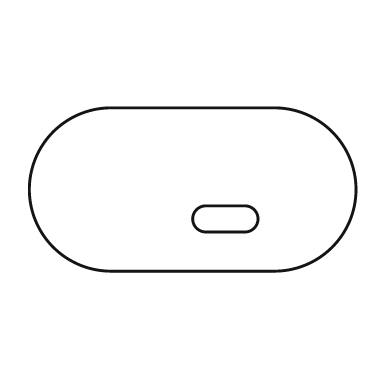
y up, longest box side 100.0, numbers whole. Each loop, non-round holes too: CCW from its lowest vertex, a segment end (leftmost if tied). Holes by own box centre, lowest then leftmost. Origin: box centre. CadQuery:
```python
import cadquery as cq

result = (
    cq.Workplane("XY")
    .moveTo(-25.0, -25.0)
    .lineTo(25.0, -25.0)
    .threePointArc((50.0, 0.0), (25.0, 25.0))
    .lineTo(-25.0, 25.0)
    .threePointArc((-50.0, 0.0), (-25.0, -25.0))
    .close()
    .moveTo(4.0, -13.0)
    .lineTo(16.0, -13.0)
    .threePointArc((20.0, -9.0), (16.0, -5.0))
    .lineTo(4.0, -5.0)
    .threePointArc((0.0, -9.0), (4.0, -13.0))
    .close()
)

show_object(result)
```